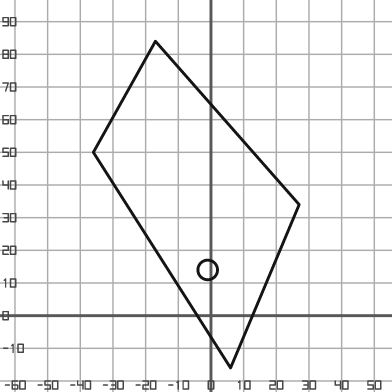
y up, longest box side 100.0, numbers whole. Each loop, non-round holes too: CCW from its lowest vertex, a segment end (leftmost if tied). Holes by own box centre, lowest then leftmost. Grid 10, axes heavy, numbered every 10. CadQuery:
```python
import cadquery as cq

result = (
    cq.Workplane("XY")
    .moveTo(6.0, -16.0)
    .lineTo(27.0, 34.0)
    .lineTo(-17.0, 84.0)
    .lineTo(-36.0, 50.0)
    .close()
    .moveTo(-1.0, 14.0)
    .circle(3.0)
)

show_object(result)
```